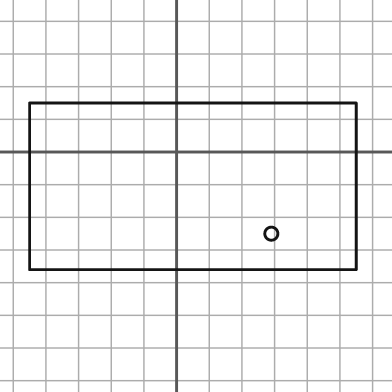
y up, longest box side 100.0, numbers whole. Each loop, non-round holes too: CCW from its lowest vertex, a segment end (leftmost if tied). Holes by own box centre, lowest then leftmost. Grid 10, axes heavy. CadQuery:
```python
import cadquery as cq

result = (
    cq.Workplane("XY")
    .moveTo(-45.0, -36.0)
    .lineTo(55.0, -36.0)
    .lineTo(55.0, 15.0)
    .lineTo(-45.0, 15.0)
    .close()
    .moveTo(29.0, -25.0)
    .circle(2.0)
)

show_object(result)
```